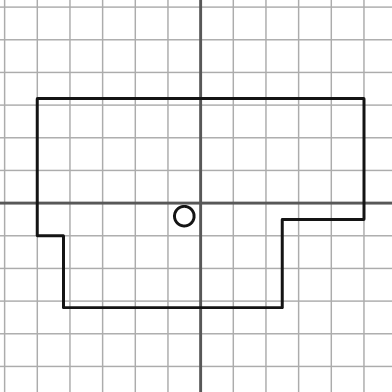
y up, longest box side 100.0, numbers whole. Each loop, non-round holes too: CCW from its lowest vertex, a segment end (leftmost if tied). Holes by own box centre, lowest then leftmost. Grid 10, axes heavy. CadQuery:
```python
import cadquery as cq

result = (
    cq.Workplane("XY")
    .moveTo(-42.0, -32.0)
    .lineTo(25.0, -32.0)
    .lineTo(25.0, -5.0)
    .lineTo(50.0, -5.0)
    .lineTo(50.0, 32.0)
    .lineTo(-50.0, 32.0)
    .lineTo(-50.0, -10.0)
    .lineTo(-42.0, -10.0)
    .close()
    .moveTo(-5.0, -4.0)
    .circle(3.0)
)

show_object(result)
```